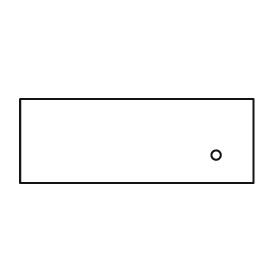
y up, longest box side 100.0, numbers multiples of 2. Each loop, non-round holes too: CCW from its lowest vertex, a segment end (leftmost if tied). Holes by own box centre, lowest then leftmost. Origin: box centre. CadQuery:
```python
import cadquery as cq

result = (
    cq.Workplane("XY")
    .moveTo(-50.0, -18.0)
    .lineTo(50.0, -18.0)
    .lineTo(50.0, 18.0)
    .lineTo(-50.0, 18.0)
    .close()
    .moveTo(34.0, -6.0)
    .circle(2.0)
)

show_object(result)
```